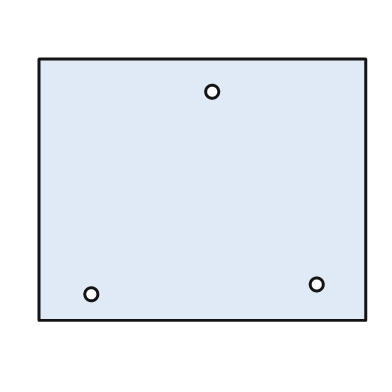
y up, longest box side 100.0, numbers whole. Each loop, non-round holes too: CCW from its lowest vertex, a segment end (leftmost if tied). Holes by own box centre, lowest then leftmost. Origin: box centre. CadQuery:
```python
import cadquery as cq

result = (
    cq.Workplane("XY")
    .moveTo(-50.0, -40.0)
    .lineTo(50.0, -40.0)
    .lineTo(50.0, 40.0)
    .lineTo(-50.0, 40.0)
    .close()
    .moveTo(-34.0, -32.0)
    .circle(2.0)
    .moveTo(35.0, -29.0)
    .circle(2.0)
    .moveTo(3.0, 30.0)
    .circle(2.0)
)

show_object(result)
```